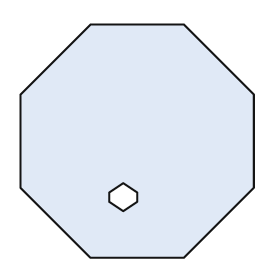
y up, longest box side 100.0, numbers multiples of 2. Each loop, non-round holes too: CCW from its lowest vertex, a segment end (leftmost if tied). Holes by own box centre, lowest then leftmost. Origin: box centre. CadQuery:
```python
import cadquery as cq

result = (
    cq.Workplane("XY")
    .moveTo(-20.0, -50.0)
    .lineTo(20.0, -50.0)
    .lineTo(50.0, -20.0)
    .lineTo(50.0, 20.0)
    .lineTo(20.0, 50.0)
    .lineTo(-20.0, 50.0)
    .lineTo(-50.0, 20.0)
    .lineTo(-50.0, -20.0)
    .close()
    .moveTo(-6.0, -30.0)
    .lineTo(0.0, -26.0)
    .lineTo(0.0, -22.0)
    .lineTo(-6.0, -18.0)
    .lineTo(-12.0, -22.0)
    .lineTo(-12.0, -26.0)
    .close()
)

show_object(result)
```